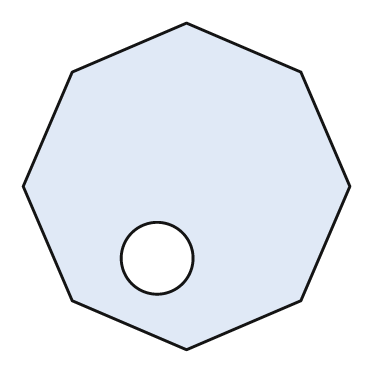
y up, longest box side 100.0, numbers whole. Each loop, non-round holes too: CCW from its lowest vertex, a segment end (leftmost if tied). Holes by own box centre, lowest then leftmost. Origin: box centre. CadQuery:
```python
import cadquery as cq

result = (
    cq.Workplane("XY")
    .moveTo(0.0, -50.0)
    .lineTo(35.0, -35.0)
    .lineTo(50.0, 0.0)
    .lineTo(35.0, 35.0)
    .lineTo(0.0, 50.0)
    .lineTo(-35.0, 35.0)
    .lineTo(-50.0, 0.0)
    .lineTo(-35.0, -35.0)
    .close()
    .moveTo(-9.0, -22.0)
    .circle(11.0)
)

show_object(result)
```